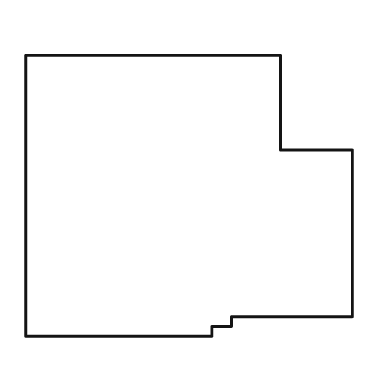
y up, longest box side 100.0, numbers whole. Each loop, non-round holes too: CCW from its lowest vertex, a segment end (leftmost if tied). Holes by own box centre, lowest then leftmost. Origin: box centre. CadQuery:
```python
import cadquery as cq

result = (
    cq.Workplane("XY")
    .moveTo(-50.0, -43.0)
    .lineTo(7.0, -43.0)
    .lineTo(7.0, -40.0)
    .lineTo(13.0, -40.0)
    .lineTo(13.0, -37.0)
    .lineTo(50.0, -37.0)
    .lineTo(50.0, 14.0)
    .lineTo(28.0, 14.0)
    .lineTo(28.0, 43.0)
    .lineTo(-50.0, 43.0)
    .close()
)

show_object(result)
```